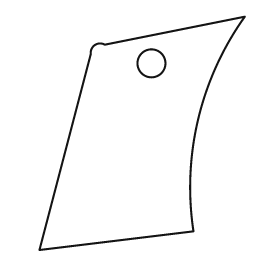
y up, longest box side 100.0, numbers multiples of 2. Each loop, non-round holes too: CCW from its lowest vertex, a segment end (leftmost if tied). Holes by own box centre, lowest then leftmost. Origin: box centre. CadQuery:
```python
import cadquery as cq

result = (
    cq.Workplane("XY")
    .moveTo(-44.0, -50.0)
    .lineTo(22.0, -42.0)
    .threePointArc((24.0, 6.0), (44.0, 50.0))
    .lineTo(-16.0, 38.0)
    .threePointArc((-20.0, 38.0), (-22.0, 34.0))
    .close()
    .moveTo(4.0, 30.0)
    .circle(6.0)
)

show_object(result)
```